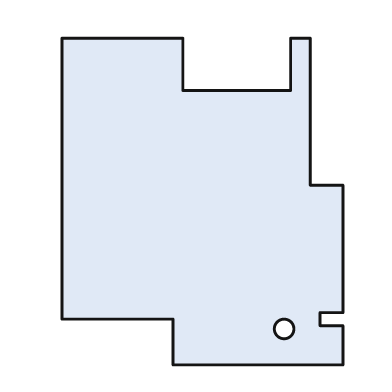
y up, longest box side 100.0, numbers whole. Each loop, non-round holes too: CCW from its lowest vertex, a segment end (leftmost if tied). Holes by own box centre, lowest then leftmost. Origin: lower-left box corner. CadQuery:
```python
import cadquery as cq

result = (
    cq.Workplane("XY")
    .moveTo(34.0, 0.0)
    .lineTo(86.0, 0.0)
    .lineTo(86.0, 12.0)
    .lineTo(79.0, 12.0)
    .lineTo(79.0, 16.0)
    .lineTo(86.0, 16.0)
    .lineTo(86.0, 55.0)
    .lineTo(76.0, 55.0)
    .lineTo(76.0, 100.0)
    .lineTo(70.0, 100.0)
    .lineTo(70.0, 84.0)
    .lineTo(37.0, 84.0)
    .lineTo(37.0, 100.0)
    .lineTo(0.0, 100.0)
    .lineTo(0.0, 14.0)
    .lineTo(34.0, 14.0)
    .close()
    .moveTo(68.0, 11.0)
    .circle(3.0)
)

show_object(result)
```